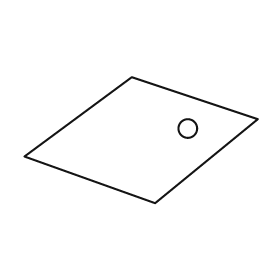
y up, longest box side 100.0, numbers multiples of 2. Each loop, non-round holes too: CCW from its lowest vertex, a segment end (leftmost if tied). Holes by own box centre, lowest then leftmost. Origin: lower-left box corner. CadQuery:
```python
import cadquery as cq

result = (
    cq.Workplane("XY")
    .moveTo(56.0, 0.0)
    .lineTo(100.0, 36.0)
    .lineTo(46.0, 54.0)
    .lineTo(0.0, 20.0)
    .close()
    .moveTo(70.0, 32.0)
    .circle(4.0)
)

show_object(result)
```